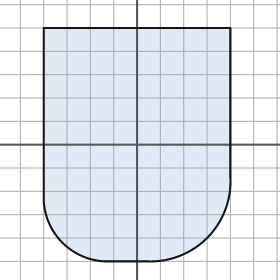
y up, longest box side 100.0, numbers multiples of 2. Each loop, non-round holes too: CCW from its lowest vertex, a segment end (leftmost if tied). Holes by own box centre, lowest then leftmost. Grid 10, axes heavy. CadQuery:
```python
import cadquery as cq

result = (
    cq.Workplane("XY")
    .moveTo(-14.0, -50.0)
    .lineTo(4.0, -50.0)
    .threePointArc((30.0, -40.0), (40.0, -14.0))
    .lineTo(40.0, 50.0)
    .lineTo(-40.0, 50.0)
    .lineTo(-40.0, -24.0)
    .threePointArc((-32.0, -42.0), (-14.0, -50.0))
    .close()
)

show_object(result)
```